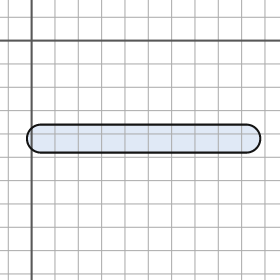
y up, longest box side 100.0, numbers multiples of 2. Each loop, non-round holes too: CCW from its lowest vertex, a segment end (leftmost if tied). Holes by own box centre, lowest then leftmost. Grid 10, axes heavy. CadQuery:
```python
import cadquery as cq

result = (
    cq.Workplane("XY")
    .moveTo(4.0, -48.0)
    .lineTo(92.0, -48.0)
    .threePointArc((98.0, -42.0), (92.0, -36.0))
    .lineTo(4.0, -36.0)
    .threePointArc((-2.0, -42.0), (4.0, -48.0))
    .close()
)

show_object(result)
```